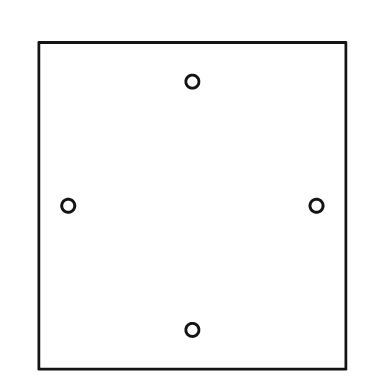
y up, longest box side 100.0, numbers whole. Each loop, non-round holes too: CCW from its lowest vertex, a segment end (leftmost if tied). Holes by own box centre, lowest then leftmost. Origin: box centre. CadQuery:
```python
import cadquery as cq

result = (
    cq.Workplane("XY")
    .moveTo(-47.0, -50.0)
    .lineTo(47.0, -50.0)
    .lineTo(47.0, 50.0)
    .lineTo(-47.0, 50.0)
    .close()
    .moveTo(0.0, -38.0)
    .circle(2.0)
    .moveTo(-38.0, 0.0)
    .circle(2.0)
    .moveTo(38.0, 0.0)
    .circle(2.0)
    .moveTo(0.0, 38.0)
    .circle(2.0)
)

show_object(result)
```